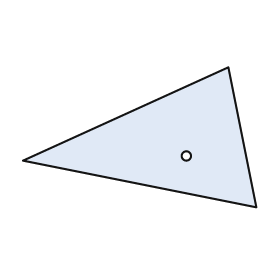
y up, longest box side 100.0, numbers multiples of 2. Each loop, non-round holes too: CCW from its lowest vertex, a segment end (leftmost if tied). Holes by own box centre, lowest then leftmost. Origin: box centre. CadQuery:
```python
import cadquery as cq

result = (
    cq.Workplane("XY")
    .moveTo(50.0, -30.0)
    .lineTo(38.0, 30.0)
    .lineTo(-50.0, -10.0)
    .close()
    .moveTo(20.0, -8.0)
    .circle(2.0)
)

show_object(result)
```